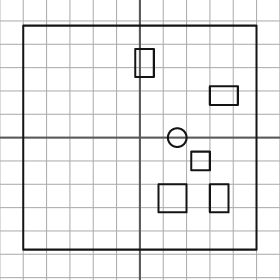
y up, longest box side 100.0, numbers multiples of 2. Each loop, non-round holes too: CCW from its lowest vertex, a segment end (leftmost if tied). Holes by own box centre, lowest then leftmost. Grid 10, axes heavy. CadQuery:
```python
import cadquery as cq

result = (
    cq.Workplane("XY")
    .moveTo(-50.0, -48.0)
    .lineTo(50.0, -48.0)
    .lineTo(50.0, 48.0)
    .lineTo(-50.0, 48.0)
    .close()
    .moveTo(8.0, -32.0)
    .lineTo(20.0, -32.0)
    .lineTo(20.0, -20.0)
    .lineTo(8.0, -20.0)
    .close()
    .moveTo(30.0, -32.0)
    .lineTo(38.0, -32.0)
    .lineTo(38.0, -20.0)
    .lineTo(30.0, -20.0)
    .close()
    .moveTo(22.0, -14.0)
    .lineTo(30.0, -14.0)
    .lineTo(30.0, -6.0)
    .lineTo(22.0, -6.0)
    .close()
    .moveTo(16.0, 0.0)
    .circle(4.0)
    .moveTo(30.0, 14.0)
    .lineTo(42.0, 14.0)
    .lineTo(42.0, 22.0)
    .lineTo(30.0, 22.0)
    .close()
    .moveTo(-2.0, 26.0)
    .lineTo(6.0, 26.0)
    .lineTo(6.0, 38.0)
    .lineTo(-2.0, 38.0)
    .close()
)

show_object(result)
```